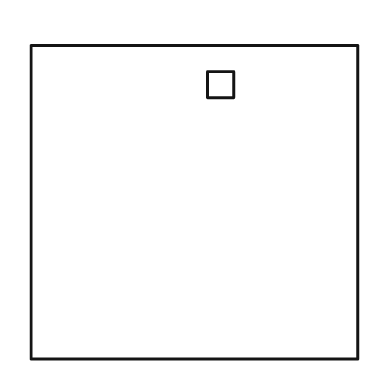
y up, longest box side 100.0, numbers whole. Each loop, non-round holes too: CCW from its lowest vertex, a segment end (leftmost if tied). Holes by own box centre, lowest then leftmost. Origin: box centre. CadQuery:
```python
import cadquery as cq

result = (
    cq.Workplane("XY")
    .moveTo(-50.0, -48.0)
    .lineTo(50.0, -48.0)
    .lineTo(50.0, 48.0)
    .lineTo(-50.0, 48.0)
    .close()
    .moveTo(4.0, 32.0)
    .lineTo(12.0, 32.0)
    .lineTo(12.0, 40.0)
    .lineTo(4.0, 40.0)
    .close()
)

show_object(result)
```